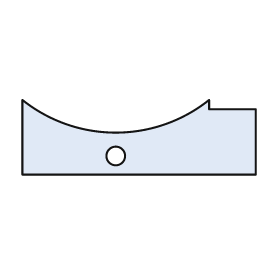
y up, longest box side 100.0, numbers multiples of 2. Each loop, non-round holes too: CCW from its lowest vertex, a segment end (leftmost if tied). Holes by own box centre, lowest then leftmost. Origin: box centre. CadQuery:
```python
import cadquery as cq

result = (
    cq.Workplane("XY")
    .moveTo(-50.0, -16.0)
    .lineTo(50.0, -16.0)
    .lineTo(50.0, 12.0)
    .lineTo(30.0, 12.0)
    .lineTo(30.0, 16.0)
    .threePointArc((-10.0, 2.0), (-50.0, 16.0))
    .close()
    .moveTo(-10.0, -8.0)
    .circle(4.0)
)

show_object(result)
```